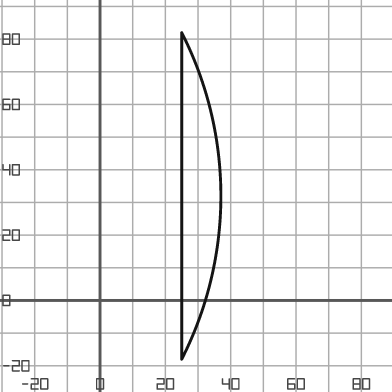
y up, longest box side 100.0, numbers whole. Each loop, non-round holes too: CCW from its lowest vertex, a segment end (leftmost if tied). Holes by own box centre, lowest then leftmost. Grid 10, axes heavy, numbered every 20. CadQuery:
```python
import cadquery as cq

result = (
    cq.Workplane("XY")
    .moveTo(25.0, -18.0)
    .threePointArc((37.0, 32.0), (25.0, 82.0))
    .close()
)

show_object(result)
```